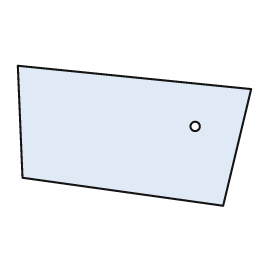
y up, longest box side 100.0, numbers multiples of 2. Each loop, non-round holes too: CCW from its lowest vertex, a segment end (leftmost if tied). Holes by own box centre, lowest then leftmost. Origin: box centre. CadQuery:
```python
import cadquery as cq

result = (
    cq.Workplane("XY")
    .moveTo(38.0, -30.0)
    .lineTo(50.0, 20.0)
    .lineTo(-50.0, 30.0)
    .lineTo(-48.0, -18.0)
    .close()
    .moveTo(26.0, 4.0)
    .circle(2.0)
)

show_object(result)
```